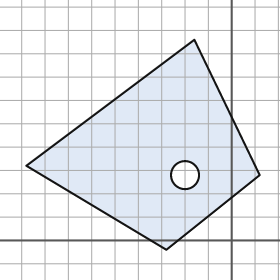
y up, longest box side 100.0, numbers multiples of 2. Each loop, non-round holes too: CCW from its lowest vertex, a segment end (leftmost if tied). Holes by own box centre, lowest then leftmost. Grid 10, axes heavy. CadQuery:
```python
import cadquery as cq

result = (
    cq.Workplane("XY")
    .moveTo(-28.0, -4.0)
    .lineTo(12.0, 28.0)
    .lineTo(-16.0, 86.0)
    .lineTo(-88.0, 32.0)
    .close()
    .moveTo(-20.0, 28.0)
    .circle(6.0)
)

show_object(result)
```